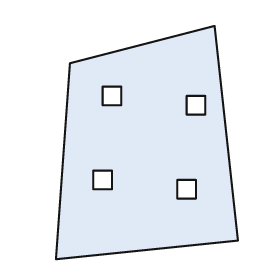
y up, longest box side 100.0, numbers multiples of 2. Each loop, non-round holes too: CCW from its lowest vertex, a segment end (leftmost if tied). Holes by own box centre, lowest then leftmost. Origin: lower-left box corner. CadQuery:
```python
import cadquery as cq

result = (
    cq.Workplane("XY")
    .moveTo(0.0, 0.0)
    .lineTo(78.0, 8.0)
    .lineTo(68.0, 100.0)
    .lineTo(6.0, 84.0)
    .close()
    .moveTo(52.0, 26.0)
    .lineTo(60.0, 26.0)
    .lineTo(60.0, 34.0)
    .lineTo(52.0, 34.0)
    .close()
    .moveTo(16.0, 30.0)
    .lineTo(24.0, 30.0)
    .lineTo(24.0, 38.0)
    .lineTo(16.0, 38.0)
    .close()
    .moveTo(56.0, 62.0)
    .lineTo(64.0, 62.0)
    .lineTo(64.0, 70.0)
    .lineTo(56.0, 70.0)
    .close()
    .moveTo(20.0, 66.0)
    .lineTo(28.0, 66.0)
    .lineTo(28.0, 74.0)
    .lineTo(20.0, 74.0)
    .close()
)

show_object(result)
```